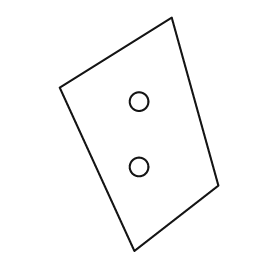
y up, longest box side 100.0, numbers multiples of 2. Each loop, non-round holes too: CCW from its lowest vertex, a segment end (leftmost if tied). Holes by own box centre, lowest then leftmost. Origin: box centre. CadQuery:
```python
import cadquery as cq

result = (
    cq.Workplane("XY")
    .moveTo(-2.0, -50.0)
    .lineTo(34.0, -22.0)
    .lineTo(14.0, 50.0)
    .lineTo(-34.0, 20.0)
    .close()
    .moveTo(0.0, -14.0)
    .circle(4.0)
    .moveTo(0.0, 14.0)
    .circle(4.0)
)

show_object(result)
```